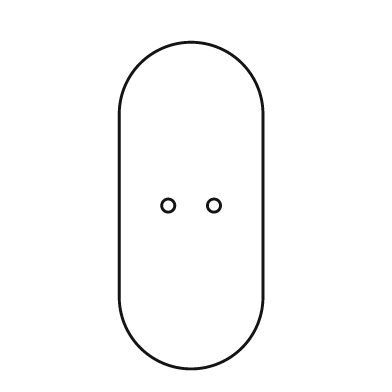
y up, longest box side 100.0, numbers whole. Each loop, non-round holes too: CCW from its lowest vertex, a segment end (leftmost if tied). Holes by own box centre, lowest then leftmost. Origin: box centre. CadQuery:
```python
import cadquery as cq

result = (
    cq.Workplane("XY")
    .moveTo(-22.0, -28.0)
    .threePointArc((0.0, -50.0), (22.0, -28.0))
    .lineTo(22.0, 28.0)
    .threePointArc((0.0, 50.0), (-22.0, 28.0))
    .close()
    .moveTo(-7.0, 0.0)
    .circle(2.0)
    .moveTo(7.0, 0.0)
    .circle(2.0)
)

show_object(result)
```